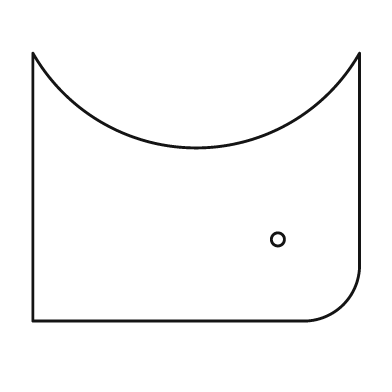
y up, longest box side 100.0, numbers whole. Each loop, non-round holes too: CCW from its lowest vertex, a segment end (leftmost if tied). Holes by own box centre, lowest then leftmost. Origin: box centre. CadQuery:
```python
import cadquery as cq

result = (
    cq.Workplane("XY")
    .moveTo(-50.0, -41.0)
    .lineTo(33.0, -41.0)
    .threePointArc((45.0, -36.0), (50.0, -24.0))
    .lineTo(50.0, 41.0)
    .threePointArc((0.0, 12.0), (-50.0, 41.0))
    .close()
    .moveTo(25.0, -16.0)
    .circle(2.0)
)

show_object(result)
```